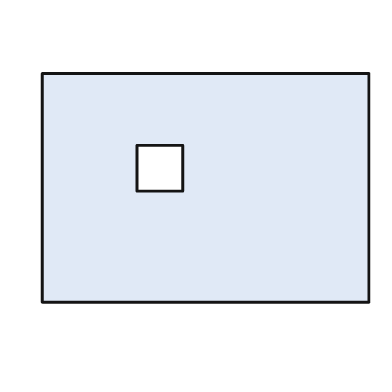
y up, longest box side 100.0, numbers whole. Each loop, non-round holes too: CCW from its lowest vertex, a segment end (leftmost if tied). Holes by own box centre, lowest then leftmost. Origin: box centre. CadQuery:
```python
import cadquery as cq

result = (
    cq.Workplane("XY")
    .moveTo(-50.0, -35.0)
    .lineTo(50.0, -35.0)
    .lineTo(50.0, 35.0)
    .lineTo(-50.0, 35.0)
    .close()
    .moveTo(-21.0, -1.0)
    .lineTo(-7.0, -1.0)
    .lineTo(-7.0, 13.0)
    .lineTo(-21.0, 13.0)
    .close()
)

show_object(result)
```